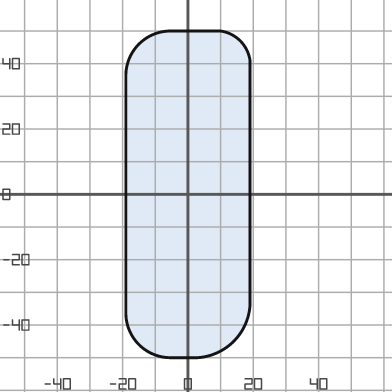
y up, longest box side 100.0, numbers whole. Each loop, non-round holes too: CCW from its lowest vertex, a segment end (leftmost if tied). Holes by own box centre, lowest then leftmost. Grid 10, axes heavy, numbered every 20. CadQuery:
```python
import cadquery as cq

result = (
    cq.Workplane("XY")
    .moveTo(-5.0, -50.0)
    .lineTo(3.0, -50.0)
    .threePointArc((14.0, -45.0), (19.0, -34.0))
    .lineTo(19.0, 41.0)
    .threePointArc((16.0, 47.0), (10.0, 50.0))
    .lineTo(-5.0, 50.0)
    .threePointArc((-15.0, 46.0), (-19.0, 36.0))
    .lineTo(-19.0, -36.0)
    .threePointArc((-15.0, -46.0), (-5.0, -50.0))
    .close()
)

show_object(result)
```